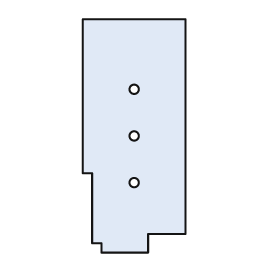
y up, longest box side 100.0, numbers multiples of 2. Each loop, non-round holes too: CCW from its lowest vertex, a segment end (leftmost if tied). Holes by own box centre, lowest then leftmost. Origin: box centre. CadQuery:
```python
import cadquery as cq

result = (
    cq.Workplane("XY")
    .moveTo(-14.0, -50.0)
    .lineTo(6.0, -50.0)
    .lineTo(6.0, -42.0)
    .lineTo(22.0, -42.0)
    .lineTo(22.0, 50.0)
    .lineTo(-22.0, 50.0)
    .lineTo(-22.0, -16.0)
    .lineTo(-18.0, -16.0)
    .lineTo(-18.0, -46.0)
    .lineTo(-14.0, -46.0)
    .close()
    .moveTo(0.0, -20.0)
    .circle(2.0)
    .moveTo(0.0, 0.0)
    .circle(2.0)
    .moveTo(0.0, 20.0)
    .circle(2.0)
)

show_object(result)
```